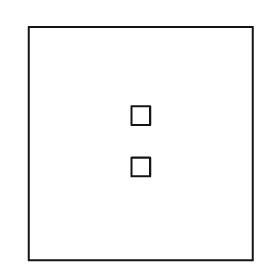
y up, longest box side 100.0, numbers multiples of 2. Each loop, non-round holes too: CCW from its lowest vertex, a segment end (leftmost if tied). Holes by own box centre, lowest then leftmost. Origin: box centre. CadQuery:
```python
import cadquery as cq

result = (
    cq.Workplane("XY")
    .moveTo(-48.0, -50.0)
    .lineTo(48.0, -50.0)
    .lineTo(48.0, 50.0)
    .lineTo(-48.0, 50.0)
    .close()
    .moveTo(-4.0, -14.0)
    .lineTo(4.0, -14.0)
    .lineTo(4.0, -6.0)
    .lineTo(-4.0, -6.0)
    .close()
    .moveTo(-4.0, 8.0)
    .lineTo(4.0, 8.0)
    .lineTo(4.0, 16.0)
    .lineTo(-4.0, 16.0)
    .close()
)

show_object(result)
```